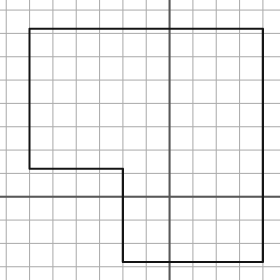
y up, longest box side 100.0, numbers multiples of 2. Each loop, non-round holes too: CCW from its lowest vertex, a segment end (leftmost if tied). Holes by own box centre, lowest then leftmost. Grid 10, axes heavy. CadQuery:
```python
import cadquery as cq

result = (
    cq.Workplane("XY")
    .moveTo(-20.0, -28.0)
    .lineTo(40.0, -28.0)
    .lineTo(40.0, 72.0)
    .lineTo(-60.0, 72.0)
    .lineTo(-60.0, 12.0)
    .lineTo(-20.0, 12.0)
    .close()
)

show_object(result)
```